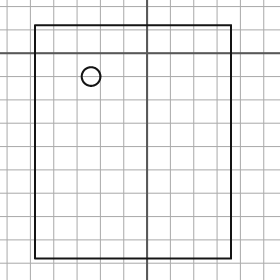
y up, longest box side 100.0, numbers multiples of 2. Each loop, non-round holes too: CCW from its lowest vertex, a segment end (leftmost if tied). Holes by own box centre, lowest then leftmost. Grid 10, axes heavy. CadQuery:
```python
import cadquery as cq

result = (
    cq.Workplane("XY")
    .moveTo(-48.0, -88.0)
    .lineTo(36.0, -88.0)
    .lineTo(36.0, 12.0)
    .lineTo(-48.0, 12.0)
    .close()
    .moveTo(-24.0, -10.0)
    .circle(4.0)
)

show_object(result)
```